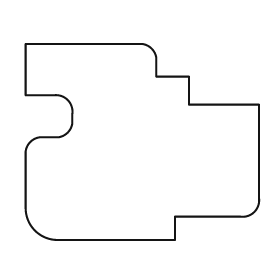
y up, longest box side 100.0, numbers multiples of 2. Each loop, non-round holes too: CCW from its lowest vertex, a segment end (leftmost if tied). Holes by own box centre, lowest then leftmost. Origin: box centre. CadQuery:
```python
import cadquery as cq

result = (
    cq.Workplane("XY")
    .moveTo(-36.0, -42.0)
    .lineTo(14.0, -42.0)
    .lineTo(14.0, -32.0)
    .lineTo(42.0, -32.0)
    .threePointArc((48.0, -30.0), (50.0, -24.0))
    .lineTo(50.0, 16.0)
    .lineTo(20.0, 16.0)
    .lineTo(20.0, 28.0)
    .lineTo(6.0, 28.0)
    .lineTo(6.0, 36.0)
    .threePointArc((4.0, 40.0), (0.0, 42.0))
    .lineTo(-50.0, 42.0)
    .lineTo(-50.0, 20.0)
    .lineTo(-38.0, 20.0)
    .threePointArc((-32.0, 18.0), (-30.0, 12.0))
    .lineTo(-30.0, 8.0)
    .threePointArc((-32.0, 4.0), (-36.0, 2.0))
    .lineTo(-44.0, 2.0)
    .threePointArc((-48.0, 0.0), (-50.0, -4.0))
    .lineTo(-50.0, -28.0)
    .threePointArc((-46.0, -38.0), (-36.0, -42.0))
    .close()
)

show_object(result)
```